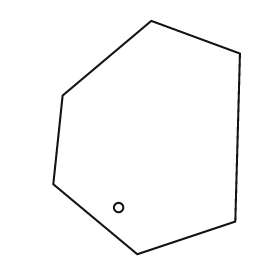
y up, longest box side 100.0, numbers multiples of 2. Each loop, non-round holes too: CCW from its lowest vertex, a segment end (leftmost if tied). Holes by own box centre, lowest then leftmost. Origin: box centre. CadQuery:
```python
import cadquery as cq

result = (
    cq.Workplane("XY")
    .moveTo(-4.0, -50.0)
    .lineTo(38.0, -36.0)
    .lineTo(40.0, 36.0)
    .lineTo(2.0, 50.0)
    .lineTo(-36.0, 18.0)
    .lineTo(-40.0, -20.0)
    .close()
    .moveTo(-12.0, -30.0)
    .circle(2.0)
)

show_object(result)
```